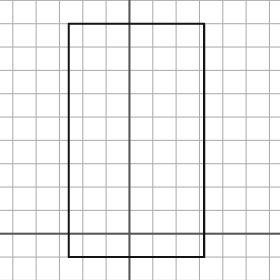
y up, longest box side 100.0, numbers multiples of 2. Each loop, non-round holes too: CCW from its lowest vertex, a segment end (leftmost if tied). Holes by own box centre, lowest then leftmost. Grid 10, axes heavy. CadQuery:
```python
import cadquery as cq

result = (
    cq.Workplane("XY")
    .moveTo(-26.0, -10.0)
    .lineTo(32.0, -10.0)
    .lineTo(32.0, 90.0)
    .lineTo(-26.0, 90.0)
    .close()
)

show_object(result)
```